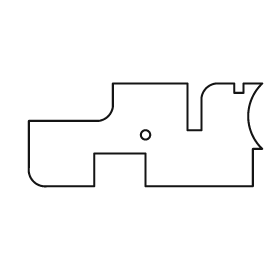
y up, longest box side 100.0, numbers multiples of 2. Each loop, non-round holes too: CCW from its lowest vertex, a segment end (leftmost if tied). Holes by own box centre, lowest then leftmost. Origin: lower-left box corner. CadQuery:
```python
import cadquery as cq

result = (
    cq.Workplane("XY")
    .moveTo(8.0, 0.0)
    .lineTo(28.0, 0.0)
    .lineTo(28.0, 14.0)
    .lineTo(50.0, 14.0)
    .lineTo(50.0, 0.0)
    .lineTo(96.0, 0.0)
    .lineTo(96.0, 16.0)
    .lineTo(100.0, 16.0)
    .threePointArc((94.0, 30.0), (100.0, 44.0))
    .lineTo(92.0, 44.0)
    .lineTo(92.0, 40.0)
    .lineTo(88.0, 40.0)
    .lineTo(88.0, 44.0)
    .lineTo(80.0, 44.0)
    .threePointArc((76.0, 42.0), (74.0, 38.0))
    .lineTo(74.0, 24.0)
    .lineTo(68.0, 24.0)
    .lineTo(68.0, 44.0)
    .lineTo(36.0, 44.0)
    .lineTo(36.0, 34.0)
    .threePointArc((34.0, 30.0), (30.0, 28.0))
    .lineTo(0.0, 28.0)
    .lineTo(0.0, 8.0)
    .threePointArc((2.0, 2.0), (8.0, 0.0))
    .close()
    .moveTo(50.0, 22.0)
    .circle(2.0)
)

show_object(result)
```